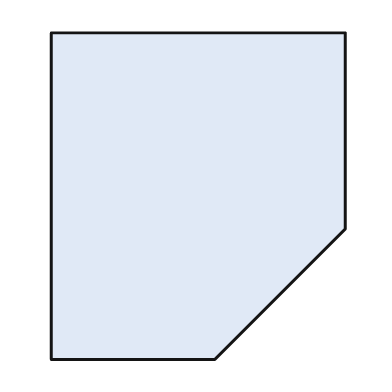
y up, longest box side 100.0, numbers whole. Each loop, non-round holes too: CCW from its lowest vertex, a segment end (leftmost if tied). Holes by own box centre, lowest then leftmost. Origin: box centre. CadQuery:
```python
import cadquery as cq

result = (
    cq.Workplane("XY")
    .moveTo(-45.0, -50.0)
    .lineTo(5.0, -50.0)
    .lineTo(45.0, -10.0)
    .lineTo(45.0, 50.0)
    .lineTo(-45.0, 50.0)
    .close()
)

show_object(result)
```